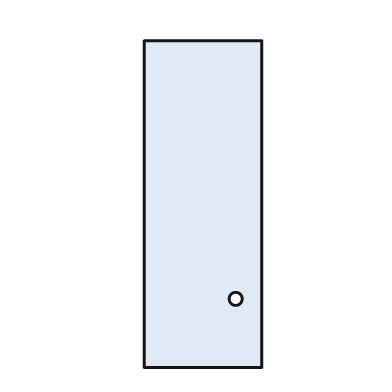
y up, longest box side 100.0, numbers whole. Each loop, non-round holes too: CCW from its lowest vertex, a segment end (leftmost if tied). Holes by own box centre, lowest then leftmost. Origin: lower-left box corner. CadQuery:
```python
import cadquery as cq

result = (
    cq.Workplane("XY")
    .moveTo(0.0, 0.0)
    .lineTo(36.0, 0.0)
    .lineTo(36.0, 100.0)
    .lineTo(0.0, 100.0)
    .close()
    .moveTo(28.0, 21.0)
    .circle(2.0)
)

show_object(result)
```